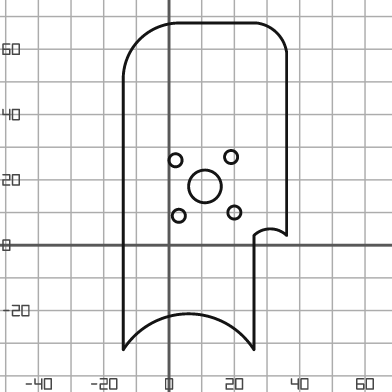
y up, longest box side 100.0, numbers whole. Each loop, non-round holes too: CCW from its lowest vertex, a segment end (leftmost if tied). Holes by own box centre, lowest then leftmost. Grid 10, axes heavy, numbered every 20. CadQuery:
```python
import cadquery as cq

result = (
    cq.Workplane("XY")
    .moveTo(-14.0, -32.0)
    .threePointArc((6.0, -21.0), (26.0, -32.0))
    .lineTo(26.0, 3.0)
    .threePointArc((31.0, 5.0), (36.0, 3.0))
    .lineTo(36.0, 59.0)
    .threePointArc((33.0, 65.0), (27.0, 68.0))
    .lineTo(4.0, 68.0)
    .threePointArc((-9.0, 63.0), (-14.0, 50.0))
    .close()
    .moveTo(3.0, 9.0)
    .circle(2.0)
    .moveTo(20.0, 10.0)
    .circle(2.0)
    .moveTo(11.0, 18.0)
    .circle(5.0)
    .moveTo(2.0, 26.0)
    .circle(2.0)
    .moveTo(19.0, 27.0)
    .circle(2.0)
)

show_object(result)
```